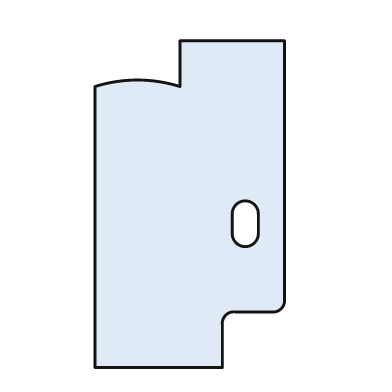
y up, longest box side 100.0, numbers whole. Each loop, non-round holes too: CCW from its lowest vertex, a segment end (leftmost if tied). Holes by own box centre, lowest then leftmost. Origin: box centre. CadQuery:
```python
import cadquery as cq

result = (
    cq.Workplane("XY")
    .moveTo(-29.0, -50.0)
    .lineTo(10.0, -50.0)
    .lineTo(10.0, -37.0)
    .threePointArc((11.0, -34.0), (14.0, -33.0))
    .lineTo(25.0, -33.0)
    .threePointArc((28.0, -32.0), (29.0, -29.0))
    .lineTo(29.0, 50.0)
    .lineTo(-3.0, 50.0)
    .lineTo(-3.0, 36.0)
    .threePointArc((-16.0, 38.0), (-29.0, 36.0))
    .close()
    .moveTo(13.0, -9.0)
    .threePointArc((17.0, -13.0), (21.0, -9.0))
    .lineTo(21.0, -3.0)
    .threePointArc((17.0, 1.0), (13.0, -3.0))
    .close()
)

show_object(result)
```